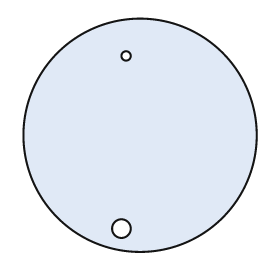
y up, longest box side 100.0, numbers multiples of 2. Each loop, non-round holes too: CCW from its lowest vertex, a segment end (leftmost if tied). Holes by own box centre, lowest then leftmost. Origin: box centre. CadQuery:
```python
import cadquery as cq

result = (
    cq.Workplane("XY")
    .moveTo(0.0, 0.0)
    .circle(50.0)
    .moveTo(-8.0, -40.0)
    .circle(4.0)
    .moveTo(-6.0, 34.0)
    .circle(2.0)
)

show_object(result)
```